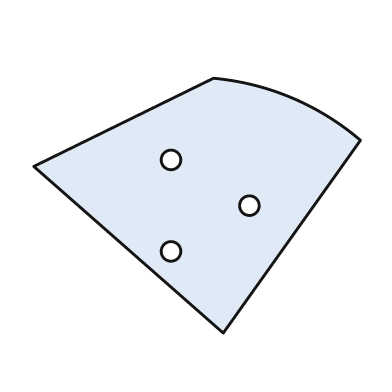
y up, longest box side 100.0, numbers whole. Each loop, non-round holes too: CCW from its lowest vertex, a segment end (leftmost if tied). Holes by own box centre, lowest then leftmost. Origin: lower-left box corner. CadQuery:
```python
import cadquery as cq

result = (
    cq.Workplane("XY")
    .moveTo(58.0, 0.0)
    .lineTo(100.0, 59.0)
    .threePointArc((79.0, 72.0), (55.0, 78.0))
    .lineTo(0.0, 51.0)
    .close()
    .moveTo(42.0, 25.0)
    .circle(3.0)
    .moveTo(66.0, 39.0)
    .circle(3.0)
    .moveTo(42.0, 53.0)
    .circle(3.0)
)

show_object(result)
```